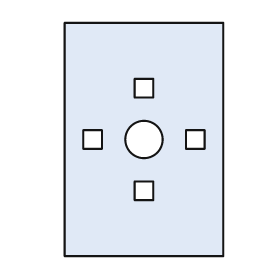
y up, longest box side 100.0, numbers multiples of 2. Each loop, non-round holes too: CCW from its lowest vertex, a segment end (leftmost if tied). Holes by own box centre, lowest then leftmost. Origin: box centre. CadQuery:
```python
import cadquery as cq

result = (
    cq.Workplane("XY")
    .moveTo(-34.0, -50.0)
    .lineTo(34.0, -50.0)
    .lineTo(34.0, 50.0)
    .lineTo(-34.0, 50.0)
    .close()
    .moveTo(-4.0, -26.0)
    .lineTo(4.0, -26.0)
    .lineTo(4.0, -18.0)
    .lineTo(-4.0, -18.0)
    .close()
    .moveTo(-26.0, -4.0)
    .lineTo(-18.0, -4.0)
    .lineTo(-18.0, 4.0)
    .lineTo(-26.0, 4.0)
    .close()
    .moveTo(0.0, 0.0)
    .circle(8.0)
    .moveTo(18.0, -4.0)
    .lineTo(26.0, -4.0)
    .lineTo(26.0, 4.0)
    .lineTo(18.0, 4.0)
    .close()
    .moveTo(-4.0, 18.0)
    .lineTo(4.0, 18.0)
    .lineTo(4.0, 26.0)
    .lineTo(-4.0, 26.0)
    .close()
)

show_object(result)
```